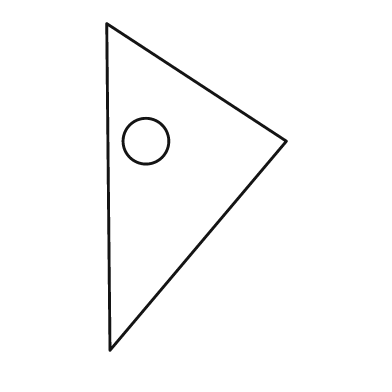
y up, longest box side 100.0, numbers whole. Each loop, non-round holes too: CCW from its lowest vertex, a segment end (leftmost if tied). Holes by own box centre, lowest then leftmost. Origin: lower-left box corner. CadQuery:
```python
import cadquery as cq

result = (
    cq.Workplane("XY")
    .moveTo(1.0, 0.0)
    .lineTo(55.0, 64.0)
    .lineTo(0.0, 100.0)
    .close()
    .moveTo(12.0, 64.0)
    .circle(7.0)
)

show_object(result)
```